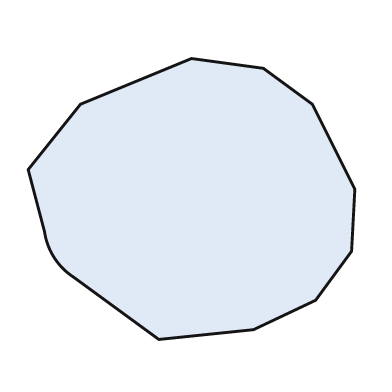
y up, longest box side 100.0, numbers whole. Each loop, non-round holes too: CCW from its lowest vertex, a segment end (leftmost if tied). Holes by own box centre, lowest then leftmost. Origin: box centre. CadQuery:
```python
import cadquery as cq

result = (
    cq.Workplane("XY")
    .moveTo(-10.0, -43.0)
    .lineTo(19.0, -40.0)
    .lineTo(38.0, -31.0)
    .lineTo(49.0, -16.0)
    .lineTo(50.0, 3.0)
    .lineTo(37.0, 29.0)
    .lineTo(22.0, 40.0)
    .lineTo(0.0, 43.0)
    .lineTo(-34.0, 29.0)
    .lineTo(-50.0, 9.0)
    .lineTo(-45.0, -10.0)
    .threePointArc((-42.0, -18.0), (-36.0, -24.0))
    .close()
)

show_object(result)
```